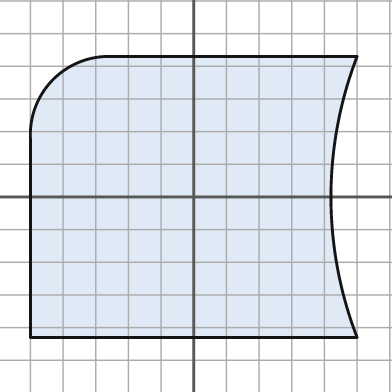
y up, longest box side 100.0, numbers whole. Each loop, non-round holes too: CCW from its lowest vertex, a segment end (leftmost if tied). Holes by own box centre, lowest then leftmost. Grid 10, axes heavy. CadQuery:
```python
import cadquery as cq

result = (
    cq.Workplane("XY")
    .moveTo(-50.0, -43.0)
    .lineTo(50.0, -43.0)
    .threePointArc((42.0, 0.0), (50.0, 43.0))
    .lineTo(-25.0, 43.0)
    .threePointArc((-43.0, 36.0), (-50.0, 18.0))
    .close()
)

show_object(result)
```